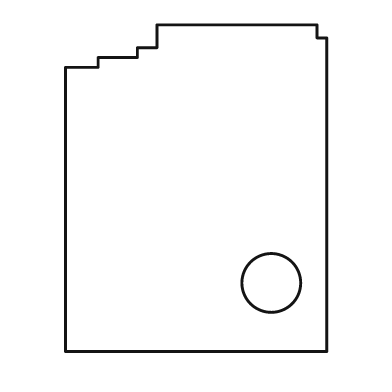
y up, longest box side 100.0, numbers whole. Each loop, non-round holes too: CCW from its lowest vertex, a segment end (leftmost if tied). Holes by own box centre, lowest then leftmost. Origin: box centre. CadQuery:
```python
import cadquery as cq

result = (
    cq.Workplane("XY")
    .moveTo(-40.0, -50.0)
    .lineTo(40.0, -50.0)
    .lineTo(40.0, 46.0)
    .lineTo(37.0, 46.0)
    .lineTo(37.0, 50.0)
    .lineTo(-12.0, 50.0)
    .lineTo(-12.0, 43.0)
    .lineTo(-18.0, 43.0)
    .lineTo(-18.0, 40.0)
    .lineTo(-30.0, 40.0)
    .lineTo(-30.0, 37.0)
    .lineTo(-40.0, 37.0)
    .close()
    .moveTo(23.0, -29.0)
    .circle(9.0)
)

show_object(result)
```